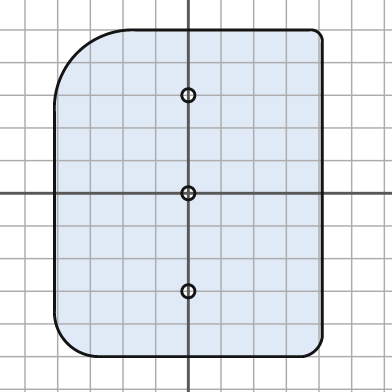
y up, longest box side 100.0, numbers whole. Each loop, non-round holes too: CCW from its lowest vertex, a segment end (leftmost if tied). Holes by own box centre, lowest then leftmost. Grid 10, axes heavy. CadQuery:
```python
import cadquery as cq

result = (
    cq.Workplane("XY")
    .moveTo(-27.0, -50.0)
    .lineTo(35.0, -50.0)
    .threePointArc((39.0, -48.0), (41.0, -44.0))
    .lineTo(41.0, 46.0)
    .threePointArc((40.0, 49.0), (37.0, 50.0))
    .lineTo(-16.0, 50.0)
    .threePointArc((-34.0, 43.0), (-41.0, 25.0))
    .lineTo(-41.0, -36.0)
    .threePointArc((-37.0, -46.0), (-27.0, -50.0))
    .close()
    .moveTo(0.0, -30.0)
    .circle(2.0)
    .moveTo(0.0, 0.0)
    .circle(2.0)
    .moveTo(0.0, 30.0)
    .circle(2.0)
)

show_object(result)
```